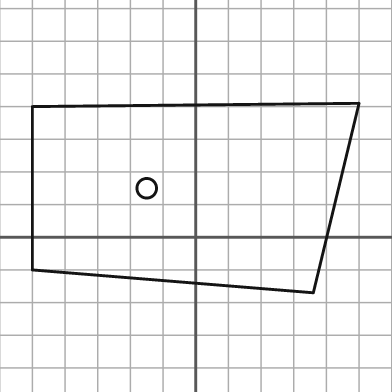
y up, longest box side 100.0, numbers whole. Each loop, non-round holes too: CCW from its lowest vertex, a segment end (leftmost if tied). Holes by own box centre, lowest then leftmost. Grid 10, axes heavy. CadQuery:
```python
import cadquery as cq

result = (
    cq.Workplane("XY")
    .moveTo(36.0, -17.0)
    .lineTo(50.0, 41.0)
    .lineTo(-50.0, 40.0)
    .lineTo(-50.0, -10.0)
    .close()
    .moveTo(-15.0, 15.0)
    .circle(3.0)
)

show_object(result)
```